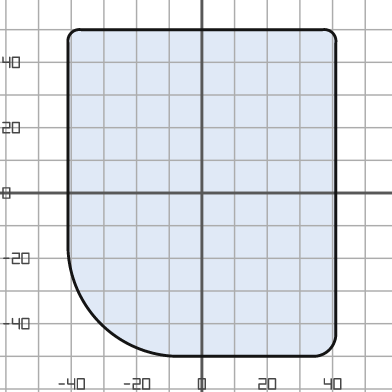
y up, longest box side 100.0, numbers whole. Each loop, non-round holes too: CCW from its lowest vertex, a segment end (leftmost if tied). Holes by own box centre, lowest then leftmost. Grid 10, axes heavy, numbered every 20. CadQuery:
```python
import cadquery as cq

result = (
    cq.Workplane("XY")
    .moveTo(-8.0, -50.0)
    .lineTo(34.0, -50.0)
    .threePointArc((39.0, -48.0), (41.0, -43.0))
    .lineTo(41.0, 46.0)
    .threePointArc((40.0, 49.0), (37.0, 50.0))
    .lineTo(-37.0, 50.0)
    .threePointArc((-40.0, 49.0), (-41.0, 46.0))
    .lineTo(-41.0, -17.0)
    .threePointArc((-31.0, -40.0), (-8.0, -50.0))
    .close()
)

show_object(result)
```